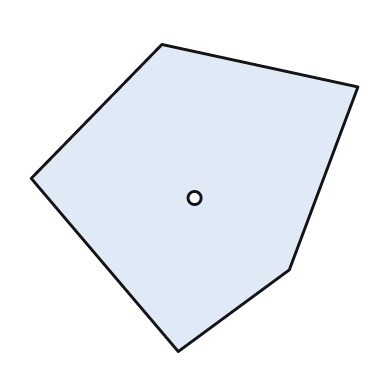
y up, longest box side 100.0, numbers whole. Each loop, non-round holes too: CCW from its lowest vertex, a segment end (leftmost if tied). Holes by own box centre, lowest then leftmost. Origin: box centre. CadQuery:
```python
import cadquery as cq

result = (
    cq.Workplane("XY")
    .moveTo(-5.0, -47.0)
    .lineTo(29.0, -22.0)
    .lineTo(50.0, 34.0)
    .lineTo(-10.0, 47.0)
    .lineTo(-50.0, 6.0)
    .close()
    .moveTo(0.0, 0.0)
    .circle(2.0)
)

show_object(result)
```